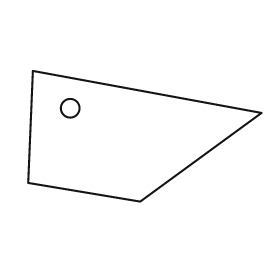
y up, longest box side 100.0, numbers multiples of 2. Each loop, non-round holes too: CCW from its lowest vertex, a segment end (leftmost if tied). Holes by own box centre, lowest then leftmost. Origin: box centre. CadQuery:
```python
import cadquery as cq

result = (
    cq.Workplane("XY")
    .moveTo(-2.0, -28.0)
    .lineTo(50.0, 10.0)
    .lineTo(-48.0, 28.0)
    .lineTo(-50.0, -20.0)
    .close()
    .moveTo(-32.0, 12.0)
    .circle(4.0)
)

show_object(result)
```